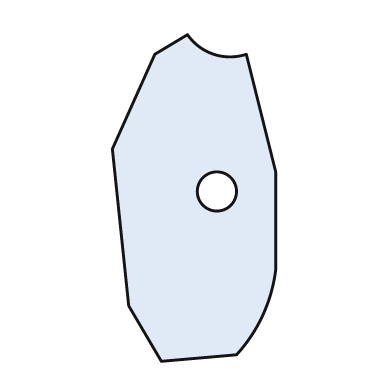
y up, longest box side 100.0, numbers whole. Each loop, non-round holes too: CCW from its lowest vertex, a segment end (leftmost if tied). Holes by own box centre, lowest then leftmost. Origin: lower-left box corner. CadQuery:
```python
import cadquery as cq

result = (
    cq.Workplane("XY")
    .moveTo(15.0, 0.0)
    .lineTo(38.0, 2.0)
    .threePointArc((46.0, 14.0), (50.0, 28.0))
    .lineTo(50.0, 58.0)
    .lineTo(41.0, 94.0)
    .threePointArc((31.0, 94.0), (23.0, 100.0))
    .lineTo(13.0, 94.0)
    .lineTo(0.0, 65.0)
    .lineTo(5.0, 17.0)
    .close()
    .moveTo(32.0, 52.0)
    .circle(6.0)
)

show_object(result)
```